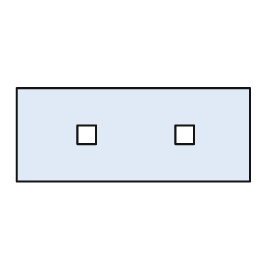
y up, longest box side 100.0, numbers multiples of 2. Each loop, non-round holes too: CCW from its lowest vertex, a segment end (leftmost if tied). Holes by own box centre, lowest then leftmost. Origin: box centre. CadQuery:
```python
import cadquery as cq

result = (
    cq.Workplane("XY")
    .moveTo(-50.0, -20.0)
    .lineTo(50.0, -20.0)
    .lineTo(50.0, 20.0)
    .lineTo(-50.0, 20.0)
    .close()
    .moveTo(-24.0, -4.0)
    .lineTo(-16.0, -4.0)
    .lineTo(-16.0, 4.0)
    .lineTo(-24.0, 4.0)
    .close()
    .moveTo(18.0, -4.0)
    .lineTo(26.0, -4.0)
    .lineTo(26.0, 4.0)
    .lineTo(18.0, 4.0)
    .close()
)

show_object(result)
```